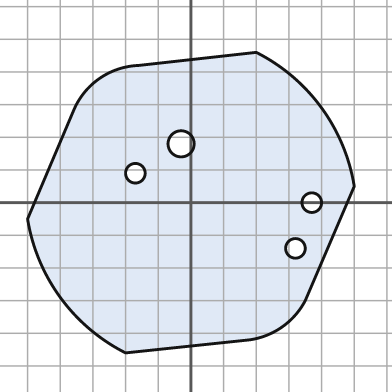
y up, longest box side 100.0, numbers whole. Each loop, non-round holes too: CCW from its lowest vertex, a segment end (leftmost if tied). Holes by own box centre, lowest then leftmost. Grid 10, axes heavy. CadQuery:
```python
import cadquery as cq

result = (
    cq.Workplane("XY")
    .moveTo(-20.0, -46.0)
    .lineTo(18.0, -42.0)
    .threePointArc((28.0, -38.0), (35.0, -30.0))
    .lineTo(50.0, 5.0)
    .threePointArc((40.0, 29.0), (20.0, 46.0))
    .lineTo(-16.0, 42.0)
    .threePointArc((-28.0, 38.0), (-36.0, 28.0))
    .lineTo(-50.0, -5.0)
    .threePointArc((-40.0, -29.0), (-20.0, -46.0))
    .close()
    .moveTo(32.0, -14.0)
    .circle(3.0)
    .moveTo(37.0, 0.0)
    .circle(3.0)
    .moveTo(-17.0, 9.0)
    .circle(3.0)
    .moveTo(-3.0, 18.0)
    .circle(4.0)
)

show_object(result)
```